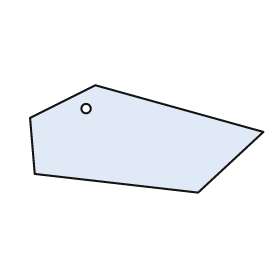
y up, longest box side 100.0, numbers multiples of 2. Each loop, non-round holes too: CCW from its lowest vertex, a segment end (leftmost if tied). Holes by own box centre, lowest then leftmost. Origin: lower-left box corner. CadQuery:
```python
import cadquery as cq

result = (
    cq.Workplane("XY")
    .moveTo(72.0, 0.0)
    .lineTo(100.0, 26.0)
    .lineTo(28.0, 46.0)
    .lineTo(0.0, 32.0)
    .lineTo(2.0, 8.0)
    .close()
    .moveTo(24.0, 36.0)
    .circle(2.0)
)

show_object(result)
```